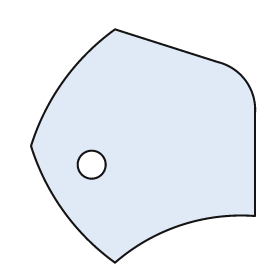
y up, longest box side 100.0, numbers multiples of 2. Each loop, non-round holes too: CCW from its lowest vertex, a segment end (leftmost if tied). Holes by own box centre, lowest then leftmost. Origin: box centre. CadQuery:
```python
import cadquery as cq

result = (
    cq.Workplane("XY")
    .moveTo(-12.0, -50.0)
    .threePointArc((16.0, -34.0), (48.0, -30.0))
    .lineTo(48.0, 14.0)
    .threePointArc((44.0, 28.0), (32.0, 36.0))
    .lineTo(-12.0, 50.0)
    .threePointArc((-34.0, 28.0), (-48.0, 0.0))
    .threePointArc((-34.0, -28.0), (-12.0, -50.0))
    .close()
    .moveTo(-22.0, -8.0)
    .circle(6.0)
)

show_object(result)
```